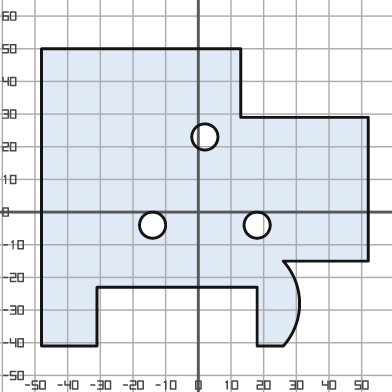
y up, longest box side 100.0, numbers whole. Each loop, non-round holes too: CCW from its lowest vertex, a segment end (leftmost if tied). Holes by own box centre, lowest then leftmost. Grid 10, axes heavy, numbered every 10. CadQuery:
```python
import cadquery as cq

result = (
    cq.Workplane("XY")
    .moveTo(-48.0, -41.0)
    .lineTo(-31.0, -41.0)
    .lineTo(-31.0, -23.0)
    .lineTo(18.0, -23.0)
    .lineTo(18.0, -41.0)
    .lineTo(26.0, -41.0)
    .threePointArc((31.0, -28.0), (26.0, -15.0))
    .lineTo(52.0, -15.0)
    .lineTo(52.0, 29.0)
    .lineTo(13.0, 29.0)
    .lineTo(13.0, 50.0)
    .lineTo(-48.0, 50.0)
    .close()
    .moveTo(-14.0, -4.0)
    .circle(4.0)
    .moveTo(18.0, -4.0)
    .circle(4.0)
    .moveTo(2.0, 23.0)
    .circle(4.0)
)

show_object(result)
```